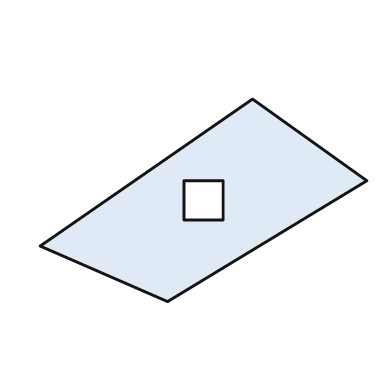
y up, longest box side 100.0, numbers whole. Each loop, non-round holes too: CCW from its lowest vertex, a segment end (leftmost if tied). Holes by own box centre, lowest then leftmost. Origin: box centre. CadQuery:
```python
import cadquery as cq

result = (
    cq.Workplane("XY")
    .moveTo(-11.0, -31.0)
    .lineTo(50.0, 6.0)
    .lineTo(15.0, 31.0)
    .lineTo(-50.0, -14.0)
    .close()
    .moveTo(-6.0, -6.0)
    .lineTo(6.0, -6.0)
    .lineTo(6.0, 6.0)
    .lineTo(-6.0, 6.0)
    .close()
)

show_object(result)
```